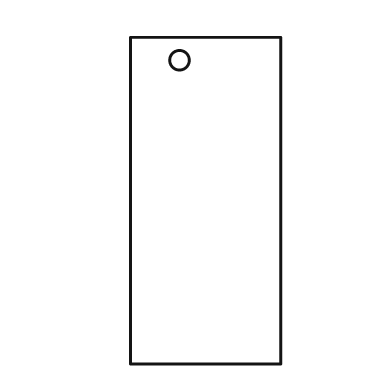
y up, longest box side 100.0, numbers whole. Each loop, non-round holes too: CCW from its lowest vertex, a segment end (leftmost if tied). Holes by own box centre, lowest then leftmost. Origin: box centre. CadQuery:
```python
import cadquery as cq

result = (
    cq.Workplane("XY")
    .moveTo(-23.0, -50.0)
    .lineTo(23.0, -50.0)
    .lineTo(23.0, 50.0)
    .lineTo(-23.0, 50.0)
    .close()
    .moveTo(-8.0, 43.0)
    .circle(3.0)
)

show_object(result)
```